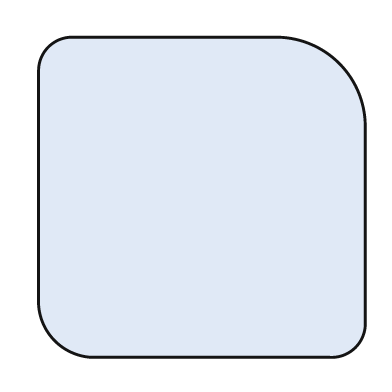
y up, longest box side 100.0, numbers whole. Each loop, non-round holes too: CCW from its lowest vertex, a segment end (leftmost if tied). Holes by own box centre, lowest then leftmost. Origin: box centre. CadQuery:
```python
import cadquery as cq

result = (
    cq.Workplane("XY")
    .moveTo(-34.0, -49.0)
    .lineTo(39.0, -49.0)
    .threePointArc((47.0, -46.0), (50.0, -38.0))
    .lineTo(50.0, 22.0)
    .threePointArc((42.0, 41.0), (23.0, 49.0))
    .lineTo(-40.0, 49.0)
    .threePointArc((-47.0, 46.0), (-50.0, 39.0))
    .lineTo(-50.0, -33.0)
    .threePointArc((-45.0, -44.0), (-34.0, -49.0))
    .close()
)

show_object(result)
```